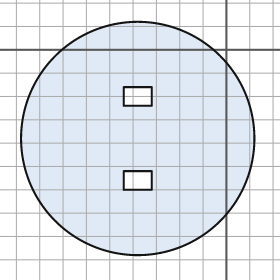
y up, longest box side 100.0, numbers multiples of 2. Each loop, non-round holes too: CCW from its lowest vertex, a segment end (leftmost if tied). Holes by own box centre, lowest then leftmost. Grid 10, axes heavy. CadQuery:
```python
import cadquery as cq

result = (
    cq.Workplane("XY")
    .moveTo(-38.0, -38.0)
    .circle(50.0)
    .moveTo(-44.0, -60.0)
    .lineTo(-32.0, -60.0)
    .lineTo(-32.0, -52.0)
    .lineTo(-44.0, -52.0)
    .close()
    .moveTo(-44.0, -24.0)
    .lineTo(-32.0, -24.0)
    .lineTo(-32.0, -16.0)
    .lineTo(-44.0, -16.0)
    .close()
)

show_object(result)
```